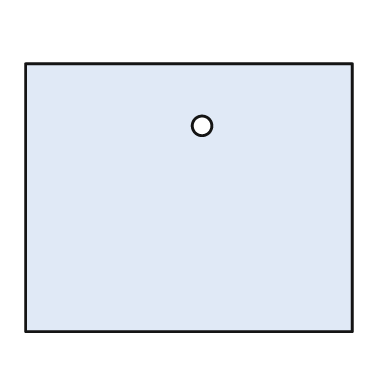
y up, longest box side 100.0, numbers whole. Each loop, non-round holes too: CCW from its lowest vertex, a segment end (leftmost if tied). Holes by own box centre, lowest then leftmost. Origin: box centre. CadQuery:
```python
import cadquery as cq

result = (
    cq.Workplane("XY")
    .moveTo(-50.0, -41.0)
    .lineTo(50.0, -41.0)
    .lineTo(50.0, 41.0)
    .lineTo(-50.0, 41.0)
    .close()
    .moveTo(4.0, 22.0)
    .circle(3.0)
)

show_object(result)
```